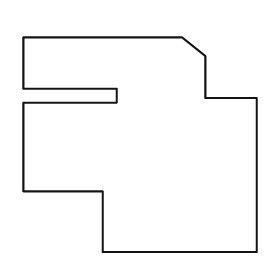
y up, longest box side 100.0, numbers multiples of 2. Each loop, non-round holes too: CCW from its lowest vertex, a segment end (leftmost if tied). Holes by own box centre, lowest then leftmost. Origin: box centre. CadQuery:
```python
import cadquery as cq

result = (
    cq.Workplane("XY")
    .moveTo(-16.0, -46.0)
    .lineTo(50.0, -46.0)
    .lineTo(50.0, 20.0)
    .lineTo(28.0, 20.0)
    .lineTo(28.0, 38.0)
    .lineTo(18.0, 46.0)
    .lineTo(-50.0, 46.0)
    .lineTo(-50.0, 24.0)
    .lineTo(-10.0, 24.0)
    .lineTo(-10.0, 18.0)
    .lineTo(-50.0, 18.0)
    .lineTo(-50.0, -20.0)
    .lineTo(-16.0, -20.0)
    .close()
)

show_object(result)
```